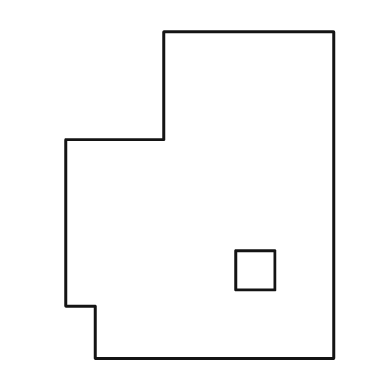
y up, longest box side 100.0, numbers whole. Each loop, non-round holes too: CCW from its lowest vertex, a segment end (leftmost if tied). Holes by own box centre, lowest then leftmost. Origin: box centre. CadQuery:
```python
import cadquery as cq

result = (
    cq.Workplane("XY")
    .moveTo(-32.0, -50.0)
    .lineTo(41.0, -50.0)
    .lineTo(41.0, 50.0)
    .lineTo(-11.0, 50.0)
    .lineTo(-11.0, 17.0)
    .lineTo(-41.0, 17.0)
    .lineTo(-41.0, -34.0)
    .lineTo(-32.0, -34.0)
    .close()
    .moveTo(11.0, -29.0)
    .lineTo(23.0, -29.0)
    .lineTo(23.0, -17.0)
    .lineTo(11.0, -17.0)
    .close()
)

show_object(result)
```